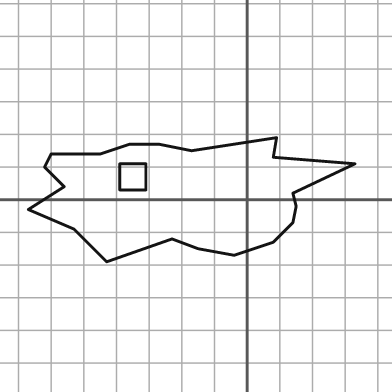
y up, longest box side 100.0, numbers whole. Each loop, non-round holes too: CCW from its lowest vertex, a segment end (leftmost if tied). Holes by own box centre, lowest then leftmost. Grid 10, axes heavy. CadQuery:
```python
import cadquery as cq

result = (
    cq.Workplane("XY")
    .moveTo(-43.0, -19.0)
    .lineTo(-23.0, -12.0)
    .lineTo(-15.0, -15.0)
    .lineTo(-4.0, -17.0)
    .lineTo(8.0, -13.0)
    .lineTo(14.0, -7.0)
    .lineTo(15.0, -2.0)
    .lineTo(14.0, 2.0)
    .lineTo(33.0, 11.0)
    .lineTo(8.0, 13.0)
    .lineTo(9.0, 19.0)
    .lineTo(-17.0, 15.0)
    .lineTo(-27.0, 17.0)
    .lineTo(-36.0, 17.0)
    .lineTo(-45.0, 14.0)
    .lineTo(-60.0, 14.0)
    .lineTo(-62.0, 10.0)
    .lineTo(-56.0, 4.0)
    .lineTo(-67.0, -3.0)
    .lineTo(-53.0, -9.0)
    .close()
    .moveTo(-39.0, 3.0)
    .lineTo(-31.0, 3.0)
    .lineTo(-31.0, 11.0)
    .lineTo(-39.0, 11.0)
    .close()
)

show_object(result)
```